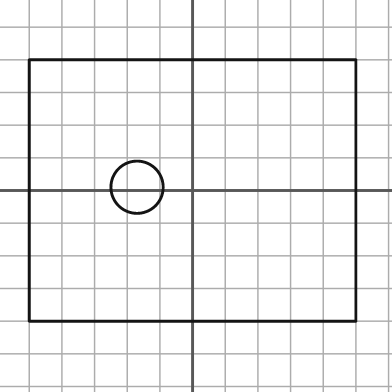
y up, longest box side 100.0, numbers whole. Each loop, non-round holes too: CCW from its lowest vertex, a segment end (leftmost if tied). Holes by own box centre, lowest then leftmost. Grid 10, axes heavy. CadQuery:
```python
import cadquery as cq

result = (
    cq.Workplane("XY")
    .moveTo(-50.0, -40.0)
    .lineTo(50.0, -40.0)
    .lineTo(50.0, 40.0)
    .lineTo(-50.0, 40.0)
    .close()
    .moveTo(-17.0, 1.0)
    .circle(8.0)
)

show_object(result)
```